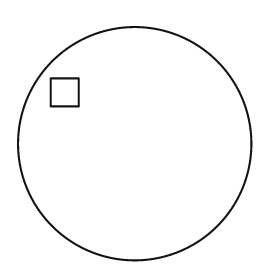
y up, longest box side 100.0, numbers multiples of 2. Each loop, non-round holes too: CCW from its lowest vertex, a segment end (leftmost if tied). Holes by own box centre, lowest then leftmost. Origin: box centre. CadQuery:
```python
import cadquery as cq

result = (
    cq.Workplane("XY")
    .moveTo(0.0, 0.0)
    .circle(50.0)
    .moveTo(-36.0, 16.0)
    .lineTo(-24.0, 16.0)
    .lineTo(-24.0, 28.0)
    .lineTo(-36.0, 28.0)
    .close()
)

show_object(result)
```